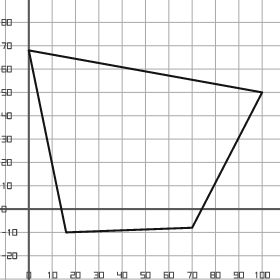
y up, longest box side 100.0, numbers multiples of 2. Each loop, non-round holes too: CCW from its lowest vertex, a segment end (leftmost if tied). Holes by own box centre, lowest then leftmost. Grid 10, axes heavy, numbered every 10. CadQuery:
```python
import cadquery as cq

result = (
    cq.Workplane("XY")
    .moveTo(16.0, -10.0)
    .lineTo(70.0, -8.0)
    .lineTo(100.0, 50.0)
    .lineTo(0.0, 68.0)
    .close()
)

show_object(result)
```